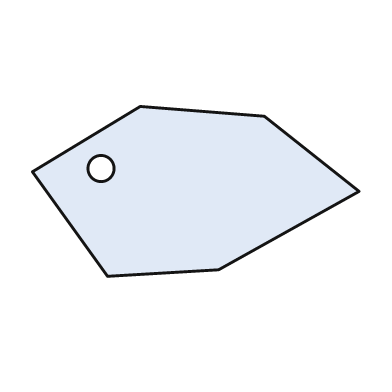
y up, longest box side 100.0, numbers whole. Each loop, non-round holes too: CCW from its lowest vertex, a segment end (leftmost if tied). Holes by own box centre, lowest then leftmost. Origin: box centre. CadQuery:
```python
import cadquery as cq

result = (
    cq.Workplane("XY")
    .moveTo(-27.0, -26.0)
    .lineTo(7.0, -24.0)
    .lineTo(50.0, 0.0)
    .lineTo(21.0, 23.0)
    .lineTo(-17.0, 26.0)
    .lineTo(-50.0, 6.0)
    .close()
    .moveTo(-29.0, 7.0)
    .circle(4.0)
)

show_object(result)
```